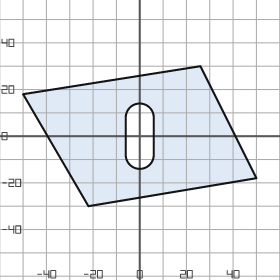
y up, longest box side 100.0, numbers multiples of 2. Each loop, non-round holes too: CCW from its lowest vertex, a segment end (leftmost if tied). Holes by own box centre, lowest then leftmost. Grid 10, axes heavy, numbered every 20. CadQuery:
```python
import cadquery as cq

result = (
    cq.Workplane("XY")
    .moveTo(-22.0, -30.0)
    .lineTo(50.0, -18.0)
    .lineTo(26.0, 30.0)
    .lineTo(-50.0, 18.0)
    .close()
    .moveTo(-6.0, -8.0)
    .threePointArc((0.0, -14.0), (6.0, -8.0))
    .lineTo(6.0, 8.0)
    .threePointArc((0.0, 14.0), (-6.0, 8.0))
    .close()
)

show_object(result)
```